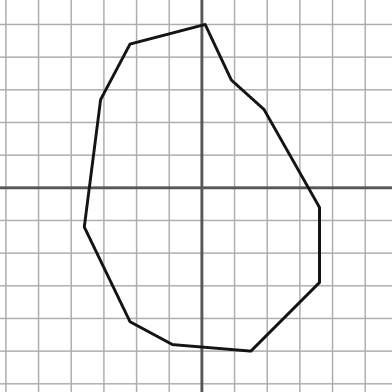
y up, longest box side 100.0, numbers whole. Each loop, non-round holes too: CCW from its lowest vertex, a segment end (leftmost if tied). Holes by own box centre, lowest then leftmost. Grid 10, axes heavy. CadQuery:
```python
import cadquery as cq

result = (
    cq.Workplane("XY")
    .moveTo(15.0, -50.0)
    .lineTo(36.0, -29.0)
    .lineTo(36.0, -6.0)
    .lineTo(19.0, 24.0)
    .lineTo(9.0, 33.0)
    .lineTo(1.0, 50.0)
    .lineTo(-22.0, 44.0)
    .lineTo(-31.0, 27.0)
    .lineTo(-36.0, -12.0)
    .lineTo(-22.0, -41.0)
    .lineTo(-9.0, -48.0)
    .close()
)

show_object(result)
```